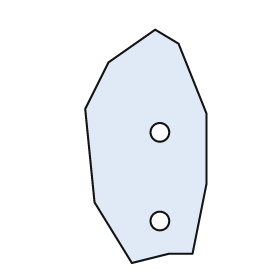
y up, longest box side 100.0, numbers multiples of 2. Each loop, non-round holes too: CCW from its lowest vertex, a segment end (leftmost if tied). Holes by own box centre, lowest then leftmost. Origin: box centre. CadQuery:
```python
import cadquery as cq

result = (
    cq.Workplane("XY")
    .moveTo(-6.0, -50.0)
    .lineTo(10.0, -46.0)
    .lineTo(20.0, -46.0)
    .lineTo(26.0, -16.0)
    .lineTo(26.0, 14.0)
    .lineTo(14.0, 44.0)
    .lineTo(4.0, 50.0)
    .lineTo(-16.0, 36.0)
    .lineTo(-26.0, 16.0)
    .lineTo(-22.0, -24.0)
    .close()
    .moveTo(6.0, -32.0)
    .circle(4.0)
    .moveTo(6.0, 6.0)
    .circle(4.0)
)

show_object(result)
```